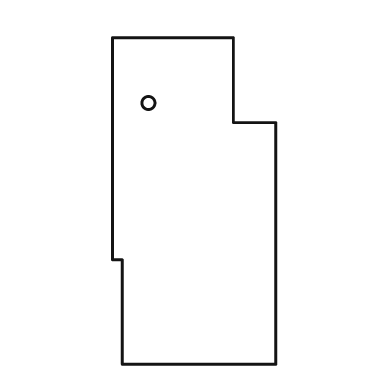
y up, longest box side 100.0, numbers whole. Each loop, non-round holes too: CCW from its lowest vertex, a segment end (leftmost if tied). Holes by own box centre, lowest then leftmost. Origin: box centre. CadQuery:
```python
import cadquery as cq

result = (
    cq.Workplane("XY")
    .moveTo(-22.0, -50.0)
    .lineTo(25.0, -50.0)
    .lineTo(25.0, 24.0)
    .lineTo(12.0, 24.0)
    .lineTo(12.0, 50.0)
    .lineTo(-25.0, 50.0)
    .lineTo(-25.0, -18.0)
    .lineTo(-22.0, -18.0)
    .close()
    .moveTo(-14.0, 30.0)
    .circle(2.0)
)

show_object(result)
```